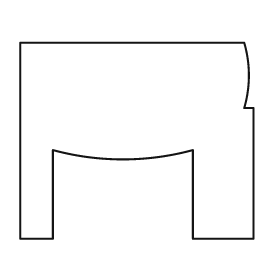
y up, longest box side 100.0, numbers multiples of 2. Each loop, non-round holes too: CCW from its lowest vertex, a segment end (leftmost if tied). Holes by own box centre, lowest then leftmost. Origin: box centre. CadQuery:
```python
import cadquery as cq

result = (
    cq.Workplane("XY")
    .moveTo(-50.0, -42.0)
    .lineTo(-36.0, -42.0)
    .lineTo(-36.0, -4.0)
    .threePointArc((-6.0, -8.0), (24.0, -4.0))
    .lineTo(24.0, -42.0)
    .lineTo(50.0, -42.0)
    .lineTo(50.0, 14.0)
    .lineTo(46.0, 14.0)
    .threePointArc((48.0, 28.0), (46.0, 42.0))
    .lineTo(-50.0, 42.0)
    .close()
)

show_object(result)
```